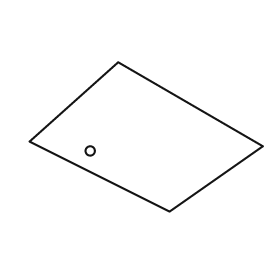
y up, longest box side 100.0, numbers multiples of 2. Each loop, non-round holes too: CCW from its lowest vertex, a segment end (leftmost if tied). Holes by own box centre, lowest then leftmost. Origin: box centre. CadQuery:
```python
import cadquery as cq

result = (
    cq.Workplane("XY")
    .moveTo(10.0, -32.0)
    .lineTo(50.0, -4.0)
    .lineTo(-12.0, 32.0)
    .lineTo(-50.0, -2.0)
    .close()
    .moveTo(-24.0, -6.0)
    .circle(2.0)
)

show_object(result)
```